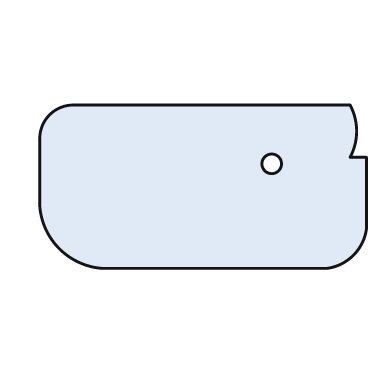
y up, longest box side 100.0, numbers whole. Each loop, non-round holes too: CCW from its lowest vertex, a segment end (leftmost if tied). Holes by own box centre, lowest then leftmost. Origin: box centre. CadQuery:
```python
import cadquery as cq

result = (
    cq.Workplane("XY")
    .moveTo(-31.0, -25.0)
    .lineTo(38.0, -25.0)
    .threePointArc((46.0, -21.0), (50.0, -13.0))
    .lineTo(50.0, 9.0)
    .lineTo(45.0, 9.0)
    .threePointArc((47.0, 17.0), (45.0, 25.0))
    .lineTo(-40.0, 25.0)
    .threePointArc((-47.0, 22.0), (-50.0, 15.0))
    .lineTo(-50.0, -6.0)
    .threePointArc((-44.0, -19.0), (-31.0, -25.0))
    .close()
    .moveTo(21.0, 7.0)
    .circle(3.0)
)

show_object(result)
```